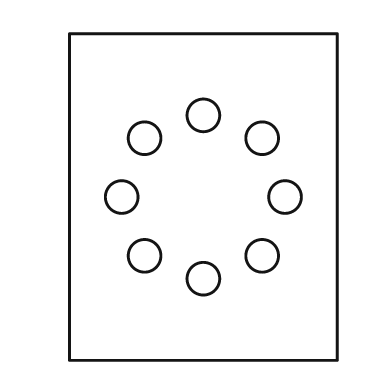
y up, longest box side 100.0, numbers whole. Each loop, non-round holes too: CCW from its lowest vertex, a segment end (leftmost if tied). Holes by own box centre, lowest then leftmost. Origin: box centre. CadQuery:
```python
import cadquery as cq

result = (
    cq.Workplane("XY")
    .moveTo(-41.0, -50.0)
    .lineTo(41.0, -50.0)
    .lineTo(41.0, 50.0)
    .lineTo(-41.0, 50.0)
    .close()
    .moveTo(0.0, -25.0)
    .circle(5.0)
    .moveTo(-18.0, -18.0)
    .circle(5.0)
    .moveTo(18.0, -18.0)
    .circle(5.0)
    .moveTo(-25.0, 0.0)
    .circle(5.0)
    .moveTo(25.0, 0.0)
    .circle(5.0)
    .moveTo(-18.0, 18.0)
    .circle(5.0)
    .moveTo(18.0, 18.0)
    .circle(5.0)
    .moveTo(0.0, 25.0)
    .circle(5.0)
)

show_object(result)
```